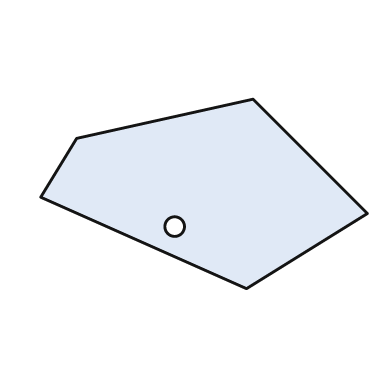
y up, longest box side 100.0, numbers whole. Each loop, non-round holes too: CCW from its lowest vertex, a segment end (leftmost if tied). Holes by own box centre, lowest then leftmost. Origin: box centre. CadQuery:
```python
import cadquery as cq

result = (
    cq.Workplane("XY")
    .moveTo(13.0, -29.0)
    .lineTo(50.0, -6.0)
    .lineTo(15.0, 29.0)
    .lineTo(-39.0, 17.0)
    .lineTo(-50.0, -1.0)
    .close()
    .moveTo(-9.0, -10.0)
    .circle(3.0)
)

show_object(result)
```